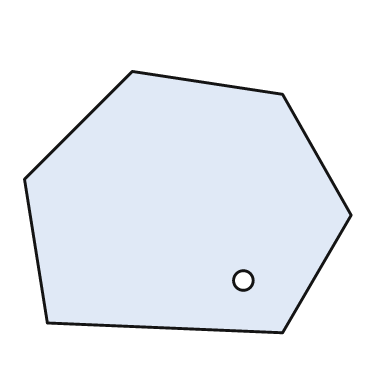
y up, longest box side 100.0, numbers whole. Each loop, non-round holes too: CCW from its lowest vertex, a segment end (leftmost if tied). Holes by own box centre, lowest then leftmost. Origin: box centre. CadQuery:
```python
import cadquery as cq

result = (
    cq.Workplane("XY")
    .moveTo(29.0, -40.0)
    .lineTo(50.0, -4.0)
    .lineTo(29.0, 33.0)
    .lineTo(-17.0, 40.0)
    .lineTo(-50.0, 7.0)
    .lineTo(-43.0, -37.0)
    .close()
    .moveTo(17.0, -24.0)
    .circle(3.0)
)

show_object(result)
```